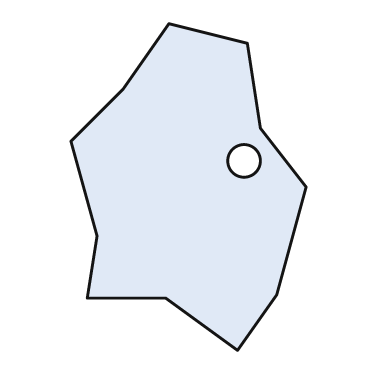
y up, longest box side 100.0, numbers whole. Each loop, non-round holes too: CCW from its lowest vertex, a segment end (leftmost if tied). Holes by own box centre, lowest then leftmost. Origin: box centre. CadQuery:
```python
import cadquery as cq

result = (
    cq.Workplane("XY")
    .moveTo(15.0, -50.0)
    .lineTo(27.0, -33.0)
    .lineTo(36.0, 0.0)
    .lineTo(22.0, 18.0)
    .lineTo(18.0, 44.0)
    .lineTo(-6.0, 50.0)
    .lineTo(-20.0, 30.0)
    .lineTo(-36.0, 14.0)
    .lineTo(-28.0, -15.0)
    .lineTo(-31.0, -34.0)
    .lineTo(-7.0, -34.0)
    .close()
    .moveTo(17.0, 8.0)
    .circle(5.0)
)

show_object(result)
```